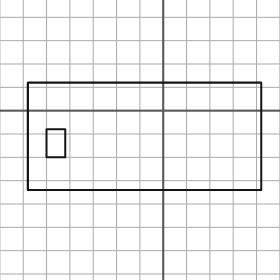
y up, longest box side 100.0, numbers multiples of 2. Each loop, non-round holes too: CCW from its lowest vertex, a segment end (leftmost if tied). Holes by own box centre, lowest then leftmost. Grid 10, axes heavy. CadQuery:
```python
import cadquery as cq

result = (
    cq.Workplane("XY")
    .moveTo(-58.0, -34.0)
    .lineTo(42.0, -34.0)
    .lineTo(42.0, 12.0)
    .lineTo(-58.0, 12.0)
    .close()
    .moveTo(-50.0, -20.0)
    .lineTo(-42.0, -20.0)
    .lineTo(-42.0, -8.0)
    .lineTo(-50.0, -8.0)
    .close()
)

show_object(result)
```